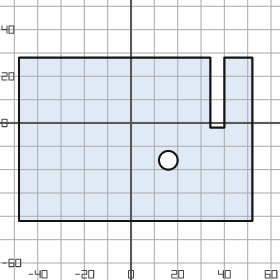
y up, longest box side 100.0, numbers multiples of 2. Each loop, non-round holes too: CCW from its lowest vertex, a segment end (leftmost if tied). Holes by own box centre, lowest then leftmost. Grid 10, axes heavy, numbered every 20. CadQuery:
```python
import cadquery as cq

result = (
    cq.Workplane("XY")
    .moveTo(-48.0, -42.0)
    .lineTo(52.0, -42.0)
    .lineTo(52.0, 28.0)
    .lineTo(40.0, 28.0)
    .lineTo(40.0, -2.0)
    .lineTo(34.0, -2.0)
    .lineTo(34.0, 28.0)
    .lineTo(-48.0, 28.0)
    .close()
    .moveTo(16.0, -16.0)
    .circle(4.0)
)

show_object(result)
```